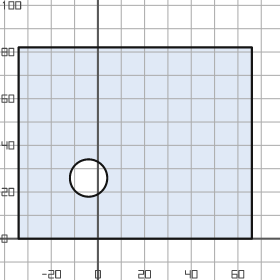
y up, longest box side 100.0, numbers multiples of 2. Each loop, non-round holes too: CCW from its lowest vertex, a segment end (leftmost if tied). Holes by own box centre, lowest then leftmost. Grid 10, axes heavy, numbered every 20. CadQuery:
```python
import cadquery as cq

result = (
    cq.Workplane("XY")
    .moveTo(-34.0, 0.0)
    .lineTo(66.0, 0.0)
    .lineTo(66.0, 82.0)
    .lineTo(-34.0, 82.0)
    .close()
    .moveTo(-4.0, 26.0)
    .circle(8.0)
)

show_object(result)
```